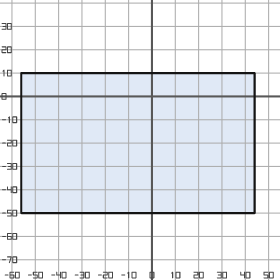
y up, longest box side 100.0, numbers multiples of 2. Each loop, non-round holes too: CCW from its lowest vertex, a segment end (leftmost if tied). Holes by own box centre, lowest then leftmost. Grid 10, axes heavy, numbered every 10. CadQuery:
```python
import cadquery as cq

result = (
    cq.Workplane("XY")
    .moveTo(-56.0, -50.0)
    .lineTo(44.0, -50.0)
    .lineTo(44.0, 10.0)
    .lineTo(-56.0, 10.0)
    .close()
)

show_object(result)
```